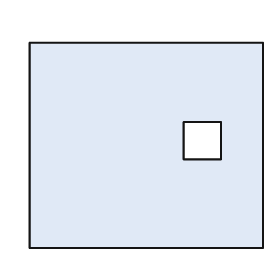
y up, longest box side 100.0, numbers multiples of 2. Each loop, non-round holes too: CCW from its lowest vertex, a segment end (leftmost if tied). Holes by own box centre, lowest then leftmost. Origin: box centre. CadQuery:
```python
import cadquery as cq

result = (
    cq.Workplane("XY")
    .moveTo(-50.0, -44.0)
    .lineTo(50.0, -44.0)
    .lineTo(50.0, 44.0)
    .lineTo(-50.0, 44.0)
    .close()
    .moveTo(16.0, -6.0)
    .lineTo(32.0, -6.0)
    .lineTo(32.0, 10.0)
    .lineTo(16.0, 10.0)
    .close()
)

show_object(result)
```